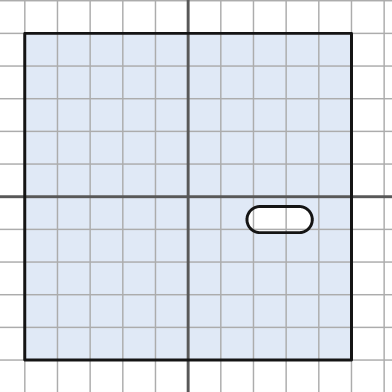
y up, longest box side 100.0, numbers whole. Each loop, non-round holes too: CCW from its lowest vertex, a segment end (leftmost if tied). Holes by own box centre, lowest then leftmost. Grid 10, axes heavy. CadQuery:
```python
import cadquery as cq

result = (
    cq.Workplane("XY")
    .moveTo(-50.0, -50.0)
    .lineTo(50.0, -50.0)
    .lineTo(50.0, 50.0)
    .lineTo(-50.0, 50.0)
    .close()
    .moveTo(22.0, -11.0)
    .lineTo(34.0, -11.0)
    .threePointArc((38.0, -7.0), (34.0, -3.0))
    .lineTo(22.0, -3.0)
    .threePointArc((18.0, -7.0), (22.0, -11.0))
    .close()
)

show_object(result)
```